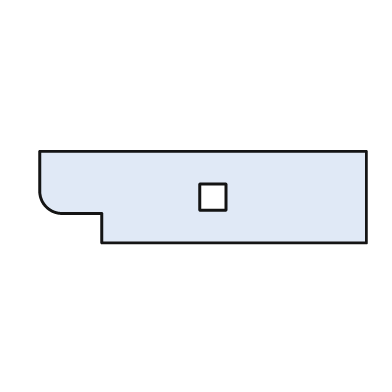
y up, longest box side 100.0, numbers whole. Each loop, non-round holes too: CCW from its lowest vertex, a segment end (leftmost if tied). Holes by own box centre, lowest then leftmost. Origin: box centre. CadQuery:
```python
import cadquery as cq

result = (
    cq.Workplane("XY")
    .moveTo(-31.0, -14.0)
    .lineTo(50.0, -14.0)
    .lineTo(50.0, 14.0)
    .lineTo(-50.0, 14.0)
    .lineTo(-50.0, 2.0)
    .threePointArc((-48.0, -3.0), (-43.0, -5.0))
    .lineTo(-31.0, -5.0)
    .close()
    .moveTo(-1.0, -4.0)
    .lineTo(7.0, -4.0)
    .lineTo(7.0, 4.0)
    .lineTo(-1.0, 4.0)
    .close()
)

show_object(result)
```